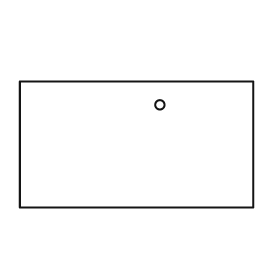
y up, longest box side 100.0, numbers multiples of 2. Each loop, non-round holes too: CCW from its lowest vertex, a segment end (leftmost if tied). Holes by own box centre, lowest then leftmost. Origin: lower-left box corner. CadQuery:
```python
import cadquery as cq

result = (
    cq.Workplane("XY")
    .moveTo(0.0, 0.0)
    .lineTo(100.0, 0.0)
    .lineTo(100.0, 54.0)
    .lineTo(0.0, 54.0)
    .close()
    .moveTo(60.0, 44.0)
    .circle(2.0)
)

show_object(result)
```